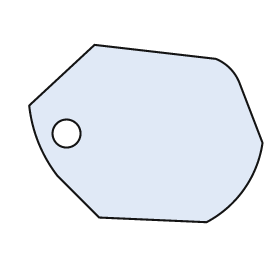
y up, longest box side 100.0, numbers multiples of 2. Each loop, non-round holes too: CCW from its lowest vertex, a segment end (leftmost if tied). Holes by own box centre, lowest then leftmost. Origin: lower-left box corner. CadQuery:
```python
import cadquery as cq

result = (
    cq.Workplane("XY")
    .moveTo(76.0, 0.0)
    .threePointArc((92.0, 14.0), (100.0, 34.0))
    .lineTo(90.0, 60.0)
    .threePointArc((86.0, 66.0), (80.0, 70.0))
    .lineTo(28.0, 76.0)
    .lineTo(0.0, 50.0)
    .threePointArc((4.0, 34.0), (12.0, 20.0))
    .lineTo(30.0, 2.0)
    .close()
    .moveTo(16.0, 38.0)
    .circle(6.0)
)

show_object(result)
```